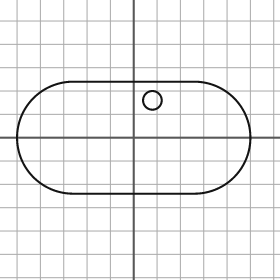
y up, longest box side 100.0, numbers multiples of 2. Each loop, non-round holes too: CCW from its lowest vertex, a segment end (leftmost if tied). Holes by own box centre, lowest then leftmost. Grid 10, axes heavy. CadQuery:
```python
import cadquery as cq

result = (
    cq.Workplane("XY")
    .moveTo(-26.0, -24.0)
    .lineTo(26.0, -24.0)
    .threePointArc((50.0, 0.0), (26.0, 24.0))
    .lineTo(-26.0, 24.0)
    .threePointArc((-50.0, 0.0), (-26.0, -24.0))
    .close()
    .moveTo(8.0, 16.0)
    .circle(4.0)
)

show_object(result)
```